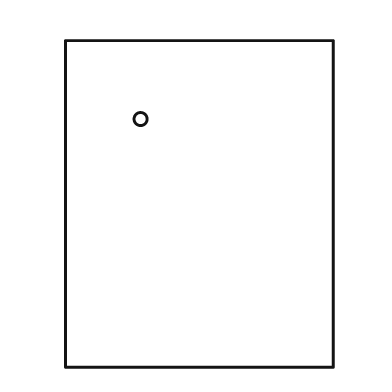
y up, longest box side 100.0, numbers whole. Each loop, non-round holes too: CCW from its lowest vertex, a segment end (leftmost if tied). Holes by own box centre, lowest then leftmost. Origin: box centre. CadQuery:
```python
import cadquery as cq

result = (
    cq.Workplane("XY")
    .moveTo(-41.0, -50.0)
    .lineTo(41.0, -50.0)
    .lineTo(41.0, 50.0)
    .lineTo(-41.0, 50.0)
    .close()
    .moveTo(-18.0, 26.0)
    .circle(2.0)
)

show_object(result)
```